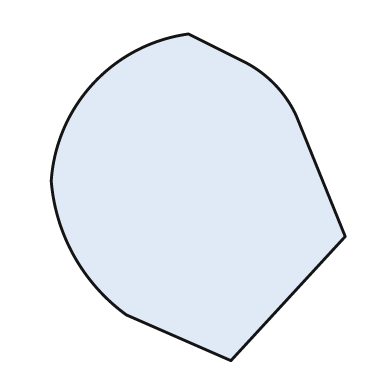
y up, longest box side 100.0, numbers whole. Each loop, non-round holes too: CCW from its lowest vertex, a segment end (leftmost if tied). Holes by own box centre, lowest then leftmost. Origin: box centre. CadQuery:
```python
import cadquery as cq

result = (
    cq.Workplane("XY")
    .moveTo(10.0, -50.0)
    .lineTo(45.0, -12.0)
    .lineTo(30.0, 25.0)
    .threePointArc((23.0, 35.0), (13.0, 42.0))
    .lineTo(-3.0, 50.0)
    .threePointArc((-32.0, 35.0), (-45.0, 5.0))
    .threePointArc((-38.0, -18.0), (-22.0, -36.0))
    .close()
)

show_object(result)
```